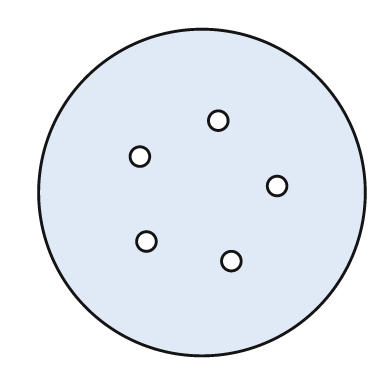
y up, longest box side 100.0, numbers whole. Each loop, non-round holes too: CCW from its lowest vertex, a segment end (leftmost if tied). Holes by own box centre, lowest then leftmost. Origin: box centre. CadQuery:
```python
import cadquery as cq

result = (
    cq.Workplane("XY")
    .moveTo(0.0, 0.0)
    .circle(50.0)
    .moveTo(9.0, -21.0)
    .circle(3.0)
    .moveTo(-17.0, -15.0)
    .circle(3.0)
    .moveTo(23.0, 2.0)
    .circle(3.0)
    .moveTo(-19.0, 11.0)
    .circle(3.0)
    .moveTo(5.0, 22.0)
    .circle(3.0)
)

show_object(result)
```